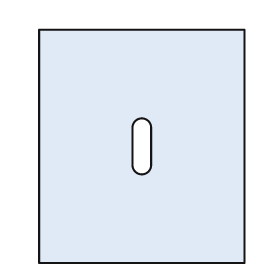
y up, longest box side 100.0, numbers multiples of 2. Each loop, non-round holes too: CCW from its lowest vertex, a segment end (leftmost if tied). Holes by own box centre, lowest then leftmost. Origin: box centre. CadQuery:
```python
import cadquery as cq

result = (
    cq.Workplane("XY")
    .moveTo(-44.0, -50.0)
    .lineTo(44.0, -50.0)
    .lineTo(44.0, 50.0)
    .lineTo(-44.0, 50.0)
    .close()
    .moveTo(-4.0, -8.0)
    .threePointArc((0.0, -12.0), (4.0, -8.0))
    .lineTo(4.0, 8.0)
    .threePointArc((0.0, 12.0), (-4.0, 8.0))
    .close()
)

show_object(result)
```